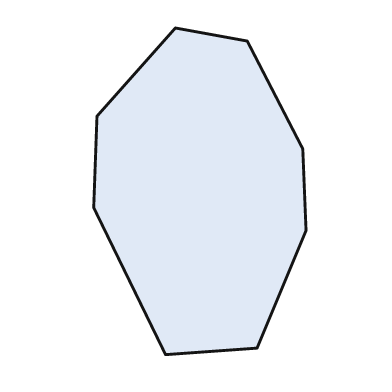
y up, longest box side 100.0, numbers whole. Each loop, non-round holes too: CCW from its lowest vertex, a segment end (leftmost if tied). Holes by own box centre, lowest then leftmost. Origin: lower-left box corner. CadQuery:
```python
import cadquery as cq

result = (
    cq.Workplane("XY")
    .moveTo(22.0, 0.0)
    .lineTo(50.0, 2.0)
    .lineTo(65.0, 38.0)
    .lineTo(64.0, 63.0)
    .lineTo(47.0, 96.0)
    .lineTo(25.0, 100.0)
    .lineTo(1.0, 73.0)
    .lineTo(0.0, 45.0)
    .close()
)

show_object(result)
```